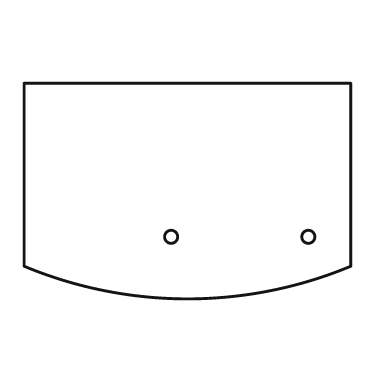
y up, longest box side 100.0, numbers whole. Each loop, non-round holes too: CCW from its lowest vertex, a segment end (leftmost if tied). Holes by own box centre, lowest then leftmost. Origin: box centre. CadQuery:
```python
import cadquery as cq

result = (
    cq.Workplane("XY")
    .moveTo(-50.0, -23.0)
    .threePointArc((0.0, -33.0), (50.0, -23.0))
    .lineTo(50.0, 33.0)
    .lineTo(-50.0, 33.0)
    .close()
    .moveTo(-5.0, -14.0)
    .circle(2.0)
    .moveTo(37.0, -14.0)
    .circle(2.0)
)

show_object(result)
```